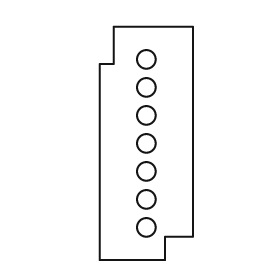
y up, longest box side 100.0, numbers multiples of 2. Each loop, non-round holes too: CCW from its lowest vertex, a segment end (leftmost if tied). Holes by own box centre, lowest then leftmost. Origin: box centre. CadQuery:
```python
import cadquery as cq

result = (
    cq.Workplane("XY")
    .moveTo(-20.0, -50.0)
    .lineTo(8.0, -50.0)
    .lineTo(8.0, -40.0)
    .lineTo(20.0, -40.0)
    .lineTo(20.0, 50.0)
    .lineTo(-14.0, 50.0)
    .lineTo(-14.0, 34.0)
    .lineTo(-20.0, 34.0)
    .close()
    .moveTo(0.0, -36.0)
    .circle(4.0)
    .moveTo(0.0, -24.0)
    .circle(4.0)
    .moveTo(0.0, -12.0)
    .circle(4.0)
    .moveTo(0.0, 0.0)
    .circle(4.0)
    .moveTo(0.0, 12.0)
    .circle(4.0)
    .moveTo(0.0, 24.0)
    .circle(4.0)
    .moveTo(0.0, 36.0)
    .circle(4.0)
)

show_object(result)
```